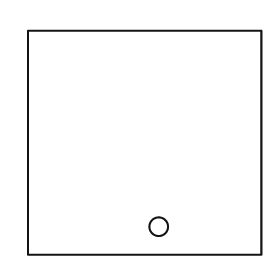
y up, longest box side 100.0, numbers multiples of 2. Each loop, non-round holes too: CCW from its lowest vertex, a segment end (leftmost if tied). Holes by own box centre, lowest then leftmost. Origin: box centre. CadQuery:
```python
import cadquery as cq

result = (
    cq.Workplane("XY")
    .moveTo(-50.0, -48.0)
    .lineTo(50.0, -48.0)
    .lineTo(50.0, 48.0)
    .lineTo(-50.0, 48.0)
    .close()
    .moveTo(6.0, -36.0)
    .circle(4.0)
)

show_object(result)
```